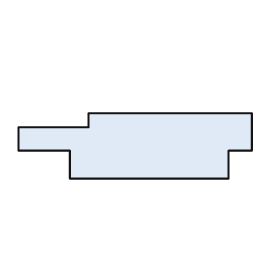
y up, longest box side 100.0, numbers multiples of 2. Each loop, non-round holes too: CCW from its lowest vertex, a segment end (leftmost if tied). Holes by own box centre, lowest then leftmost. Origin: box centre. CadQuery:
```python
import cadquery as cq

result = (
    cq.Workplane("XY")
    .moveTo(-28.0, -14.0)
    .lineTo(40.0, -14.0)
    .lineTo(40.0, -2.0)
    .lineTo(50.0, -2.0)
    .lineTo(50.0, 14.0)
    .lineTo(-20.0, 14.0)
    .lineTo(-20.0, 8.0)
    .lineTo(-50.0, 8.0)
    .lineTo(-50.0, -2.0)
    .lineTo(-28.0, -2.0)
    .close()
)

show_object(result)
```